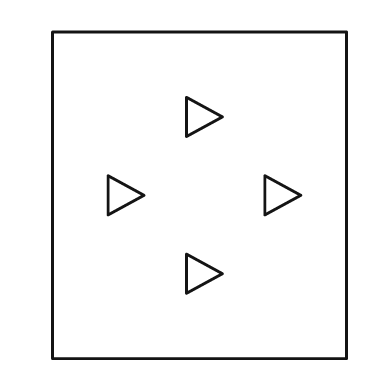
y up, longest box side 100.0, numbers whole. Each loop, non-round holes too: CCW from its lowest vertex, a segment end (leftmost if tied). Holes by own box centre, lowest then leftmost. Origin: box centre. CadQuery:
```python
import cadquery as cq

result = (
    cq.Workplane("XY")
    .moveTo(-45.0, -50.0)
    .lineTo(45.0, -50.0)
    .lineTo(45.0, 50.0)
    .lineTo(-45.0, 50.0)
    .close()
    .moveTo(-4.0, -30.0)
    .lineTo(7.0, -24.0)
    .lineTo(-4.0, -18.0)
    .close()
    .moveTo(-28.0, -6.0)
    .lineTo(-17.0, 0.0)
    .lineTo(-28.0, 6.0)
    .close()
    .moveTo(20.0, -6.0)
    .lineTo(31.0, 0.0)
    .lineTo(20.0, 6.0)
    .close()
    .moveTo(-4.0, 18.0)
    .lineTo(7.0, 24.0)
    .lineTo(-4.0, 30.0)
    .close()
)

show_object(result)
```